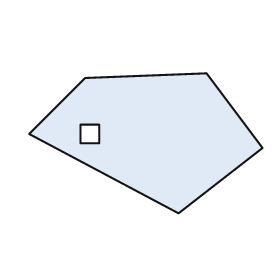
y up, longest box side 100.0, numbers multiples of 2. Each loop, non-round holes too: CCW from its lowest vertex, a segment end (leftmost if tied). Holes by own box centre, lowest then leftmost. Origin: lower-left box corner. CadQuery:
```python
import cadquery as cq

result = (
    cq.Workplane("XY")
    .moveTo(64.0, 0.0)
    .lineTo(100.0, 28.0)
    .lineTo(76.0, 60.0)
    .lineTo(24.0, 58.0)
    .lineTo(0.0, 34.0)
    .close()
    .moveTo(22.0, 30.0)
    .lineTo(30.0, 30.0)
    .lineTo(30.0, 38.0)
    .lineTo(22.0, 38.0)
    .close()
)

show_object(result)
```